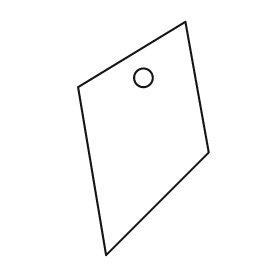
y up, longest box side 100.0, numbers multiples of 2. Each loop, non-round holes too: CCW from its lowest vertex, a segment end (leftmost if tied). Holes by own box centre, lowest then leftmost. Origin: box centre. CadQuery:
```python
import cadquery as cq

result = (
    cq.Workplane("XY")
    .moveTo(-16.0, -50.0)
    .lineTo(28.0, -6.0)
    .lineTo(18.0, 50.0)
    .lineTo(-28.0, 22.0)
    .close()
    .moveTo(0.0, 26.0)
    .circle(4.0)
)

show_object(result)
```